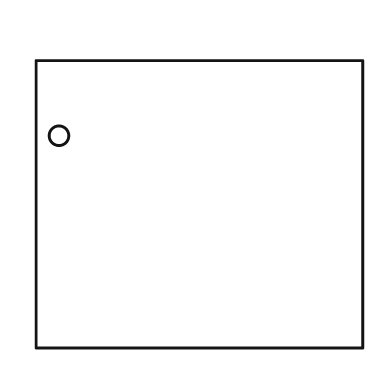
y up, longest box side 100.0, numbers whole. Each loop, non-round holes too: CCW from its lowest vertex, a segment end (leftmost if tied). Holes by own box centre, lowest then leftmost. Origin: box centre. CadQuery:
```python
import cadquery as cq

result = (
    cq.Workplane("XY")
    .moveTo(-50.0, -44.0)
    .lineTo(50.0, -44.0)
    .lineTo(50.0, 44.0)
    .lineTo(-50.0, 44.0)
    .close()
    .moveTo(-43.0, 21.0)
    .circle(3.0)
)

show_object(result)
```